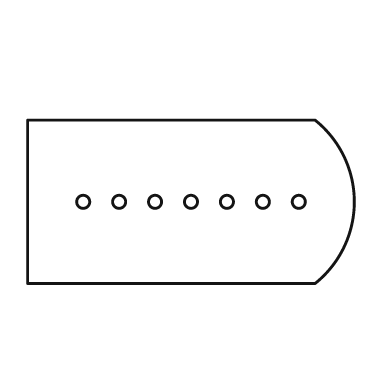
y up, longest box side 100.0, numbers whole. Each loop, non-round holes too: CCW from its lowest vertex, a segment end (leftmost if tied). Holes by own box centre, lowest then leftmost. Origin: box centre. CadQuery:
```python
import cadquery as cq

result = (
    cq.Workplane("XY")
    .moveTo(-50.0, -25.0)
    .lineTo(38.0, -25.0)
    .threePointArc((50.0, 0.0), (38.0, 25.0))
    .lineTo(-50.0, 25.0)
    .close()
    .moveTo(-33.0, 0.0)
    .circle(2.0)
    .moveTo(-22.0, 0.0)
    .circle(2.0)
    .moveTo(-11.0, 0.0)
    .circle(2.0)
    .moveTo(0.0, 0.0)
    .circle(2.0)
    .moveTo(11.0, 0.0)
    .circle(2.0)
    .moveTo(22.0, 0.0)
    .circle(2.0)
    .moveTo(33.0, 0.0)
    .circle(2.0)
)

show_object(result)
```